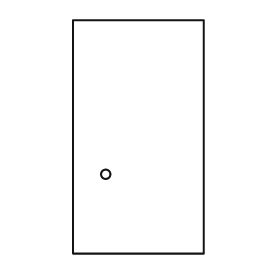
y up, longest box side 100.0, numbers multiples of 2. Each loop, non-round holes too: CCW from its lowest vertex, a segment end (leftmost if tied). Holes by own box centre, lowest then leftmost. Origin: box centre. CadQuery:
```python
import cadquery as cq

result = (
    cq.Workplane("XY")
    .moveTo(-28.0, -50.0)
    .lineTo(28.0, -50.0)
    .lineTo(28.0, 50.0)
    .lineTo(-28.0, 50.0)
    .close()
    .moveTo(-14.0, -16.0)
    .circle(2.0)
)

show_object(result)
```